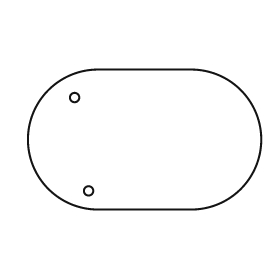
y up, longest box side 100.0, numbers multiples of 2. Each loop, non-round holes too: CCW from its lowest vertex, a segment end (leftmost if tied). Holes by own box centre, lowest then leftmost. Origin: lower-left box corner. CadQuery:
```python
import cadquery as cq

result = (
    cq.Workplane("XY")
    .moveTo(30.0, 0.0)
    .lineTo(70.0, 0.0)
    .threePointArc((100.0, 30.0), (70.0, 60.0))
    .lineTo(30.0, 60.0)
    .threePointArc((0.0, 30.0), (30.0, 0.0))
    .close()
    .moveTo(26.0, 8.0)
    .circle(2.0)
    .moveTo(20.0, 48.0)
    .circle(2.0)
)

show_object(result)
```